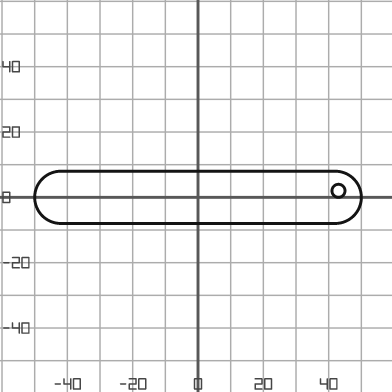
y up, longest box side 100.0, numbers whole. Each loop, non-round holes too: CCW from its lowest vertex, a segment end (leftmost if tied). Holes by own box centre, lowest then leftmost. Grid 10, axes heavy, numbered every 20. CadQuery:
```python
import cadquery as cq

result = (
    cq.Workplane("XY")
    .moveTo(-42.0, -8.0)
    .lineTo(42.0, -8.0)
    .threePointArc((50.0, 0.0), (42.0, 8.0))
    .lineTo(-42.0, 8.0)
    .threePointArc((-50.0, 0.0), (-42.0, -8.0))
    .close()
    .moveTo(43.0, 2.0)
    .circle(2.0)
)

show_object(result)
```